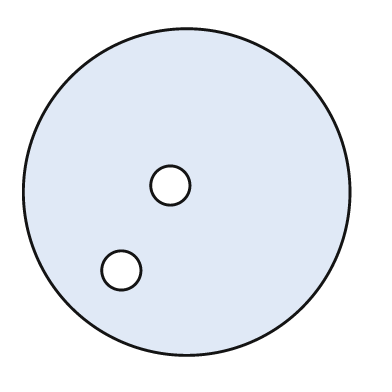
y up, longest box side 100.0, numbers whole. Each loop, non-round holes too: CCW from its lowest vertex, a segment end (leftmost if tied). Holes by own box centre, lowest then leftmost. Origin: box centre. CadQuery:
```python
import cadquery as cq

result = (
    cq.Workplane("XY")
    .moveTo(0.0, 0.0)
    .circle(50.0)
    .moveTo(-20.0, -24.0)
    .circle(6.0)
    .moveTo(-5.0, 2.0)
    .circle(6.0)
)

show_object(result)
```